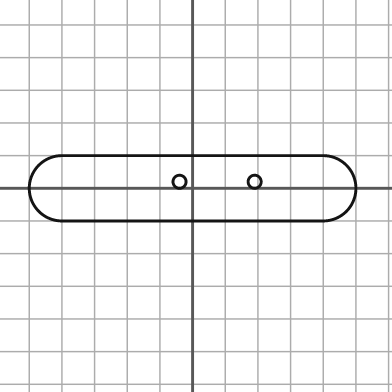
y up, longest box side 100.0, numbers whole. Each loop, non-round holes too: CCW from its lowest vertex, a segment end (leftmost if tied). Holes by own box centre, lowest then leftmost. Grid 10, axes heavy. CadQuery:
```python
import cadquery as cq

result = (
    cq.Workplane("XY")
    .moveTo(-40.0, -10.0)
    .lineTo(40.0, -10.0)
    .threePointArc((50.0, 0.0), (40.0, 10.0))
    .lineTo(-40.0, 10.0)
    .threePointArc((-50.0, 0.0), (-40.0, -10.0))
    .close()
    .moveTo(-4.0, 2.0)
    .circle(2.0)
    .moveTo(19.0, 2.0)
    .circle(2.0)
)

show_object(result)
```